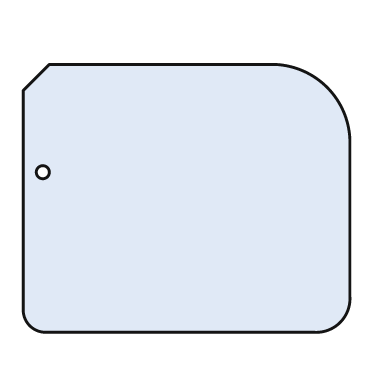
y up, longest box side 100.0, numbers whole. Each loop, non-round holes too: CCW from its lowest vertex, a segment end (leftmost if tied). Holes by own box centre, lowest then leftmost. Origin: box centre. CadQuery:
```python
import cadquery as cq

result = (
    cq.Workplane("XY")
    .moveTo(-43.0, -41.0)
    .lineTo(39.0, -41.0)
    .threePointArc((47.0, -38.0), (50.0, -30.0))
    .lineTo(50.0, 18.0)
    .threePointArc((43.0, 34.0), (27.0, 41.0))
    .lineTo(-42.0, 41.0)
    .lineTo(-50.0, 33.0)
    .lineTo(-50.0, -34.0)
    .threePointArc((-48.0, -39.0), (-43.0, -41.0))
    .close()
    .moveTo(-44.0, 8.0)
    .circle(2.0)
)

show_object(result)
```